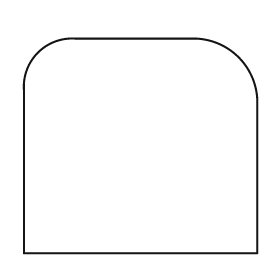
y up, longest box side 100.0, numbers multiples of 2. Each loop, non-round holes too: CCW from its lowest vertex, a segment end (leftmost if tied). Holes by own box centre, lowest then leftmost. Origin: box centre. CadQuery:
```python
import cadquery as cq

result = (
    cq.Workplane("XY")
    .moveTo(-50.0, -46.0)
    .lineTo(50.0, -46.0)
    .lineTo(50.0, 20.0)
    .threePointArc((42.0, 38.0), (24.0, 46.0))
    .lineTo(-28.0, 46.0)
    .threePointArc((-44.0, 40.0), (-50.0, 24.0))
    .close()
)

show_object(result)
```